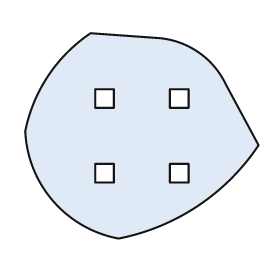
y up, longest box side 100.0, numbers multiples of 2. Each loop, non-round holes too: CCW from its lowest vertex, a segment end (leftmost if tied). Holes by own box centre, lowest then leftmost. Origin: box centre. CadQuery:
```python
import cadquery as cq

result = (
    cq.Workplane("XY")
    .moveTo(-10.0, -44.0)
    .threePointArc((24.0, -30.0), (50.0, -4.0))
    .lineTo(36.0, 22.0)
    .threePointArc((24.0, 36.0), (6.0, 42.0))
    .lineTo(-22.0, 44.0)
    .threePointArc((-40.0, 26.0), (-50.0, 2.0))
    .threePointArc((-38.0, -28.0), (-10.0, -44.0))
    .close()
    .moveTo(-20.0, -20.0)
    .lineTo(-12.0, -20.0)
    .lineTo(-12.0, -12.0)
    .lineTo(-20.0, -12.0)
    .close()
    .moveTo(12.0, -20.0)
    .lineTo(20.0, -20.0)
    .lineTo(20.0, -12.0)
    .lineTo(12.0, -12.0)
    .close()
    .moveTo(-20.0, 12.0)
    .lineTo(-12.0, 12.0)
    .lineTo(-12.0, 20.0)
    .lineTo(-20.0, 20.0)
    .close()
    .moveTo(12.0, 12.0)
    .lineTo(20.0, 12.0)
    .lineTo(20.0, 20.0)
    .lineTo(12.0, 20.0)
    .close()
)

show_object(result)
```